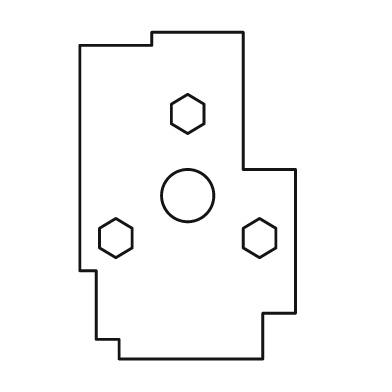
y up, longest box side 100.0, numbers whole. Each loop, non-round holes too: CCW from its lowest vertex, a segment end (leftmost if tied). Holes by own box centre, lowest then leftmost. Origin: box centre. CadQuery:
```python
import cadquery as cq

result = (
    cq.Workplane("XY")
    .moveTo(-21.0, -50.0)
    .lineTo(23.0, -50.0)
    .lineTo(23.0, -36.0)
    .lineTo(33.0, -36.0)
    .lineTo(33.0, 8.0)
    .lineTo(17.0, 8.0)
    .lineTo(17.0, 50.0)
    .lineTo(-11.0, 50.0)
    .lineTo(-11.0, 46.0)
    .lineTo(-33.0, 46.0)
    .lineTo(-33.0, -23.0)
    .lineTo(-28.0, -23.0)
    .lineTo(-28.0, -44.0)
    .lineTo(-21.0, -44.0)
    .close()
    .moveTo(-22.0, -19.0)
    .lineTo(-17.0, -16.0)
    .lineTo(-17.0, -10.0)
    .lineTo(-22.0, -7.0)
    .lineTo(-27.0, -10.0)
    .lineTo(-27.0, -16.0)
    .close()
    .moveTo(22.0, -19.0)
    .lineTo(27.0, -16.0)
    .lineTo(27.0, -10.0)
    .lineTo(22.0, -7.0)
    .lineTo(17.0, -10.0)
    .lineTo(17.0, -16.0)
    .close()
    .moveTo(0.0, 0.0)
    .circle(8.0)
    .moveTo(0.0, 19.0)
    .lineTo(5.0, 22.0)
    .lineTo(5.0, 28.0)
    .lineTo(0.0, 31.0)
    .lineTo(-5.0, 28.0)
    .lineTo(-5.0, 22.0)
    .close()
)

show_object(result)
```